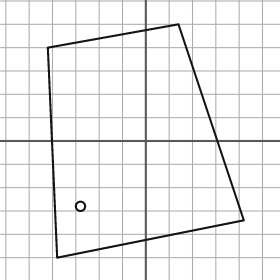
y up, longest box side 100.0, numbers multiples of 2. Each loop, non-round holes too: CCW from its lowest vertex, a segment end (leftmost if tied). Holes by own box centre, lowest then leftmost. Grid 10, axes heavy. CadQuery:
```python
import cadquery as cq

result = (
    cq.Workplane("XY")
    .moveTo(-38.0, -50.0)
    .lineTo(42.0, -34.0)
    .lineTo(14.0, 50.0)
    .lineTo(-42.0, 40.0)
    .close()
    .moveTo(-28.0, -28.0)
    .circle(2.0)
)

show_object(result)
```